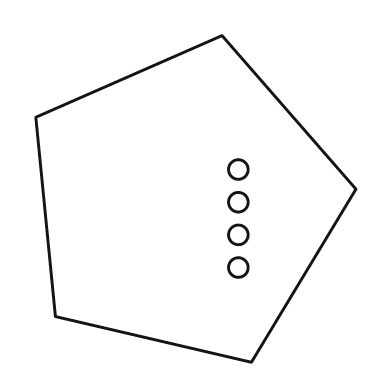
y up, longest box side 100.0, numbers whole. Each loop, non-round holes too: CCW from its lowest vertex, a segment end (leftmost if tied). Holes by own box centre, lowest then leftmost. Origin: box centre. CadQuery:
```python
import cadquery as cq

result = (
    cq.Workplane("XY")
    .moveTo(17.0, -50.0)
    .lineTo(49.0, 3.0)
    .lineTo(8.0, 50.0)
    .lineTo(-49.0, 25.0)
    .lineTo(-43.0, -36.0)
    .close()
    .moveTo(13.0, -21.0)
    .circle(3.0)
    .moveTo(13.0, -11.0)
    .circle(3.0)
    .moveTo(13.0, -1.0)
    .circle(3.0)
    .moveTo(13.0, 9.0)
    .circle(3.0)
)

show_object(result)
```